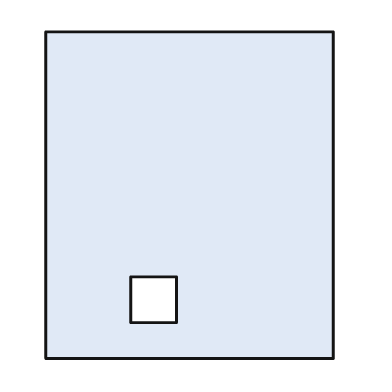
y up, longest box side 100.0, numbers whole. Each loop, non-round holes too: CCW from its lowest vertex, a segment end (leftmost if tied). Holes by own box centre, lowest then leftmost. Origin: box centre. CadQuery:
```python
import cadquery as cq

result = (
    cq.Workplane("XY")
    .moveTo(-44.0, -50.0)
    .lineTo(44.0, -50.0)
    .lineTo(44.0, 50.0)
    .lineTo(-44.0, 50.0)
    .close()
    .moveTo(-18.0, -39.0)
    .lineTo(-4.0, -39.0)
    .lineTo(-4.0, -25.0)
    .lineTo(-18.0, -25.0)
    .close()
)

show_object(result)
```